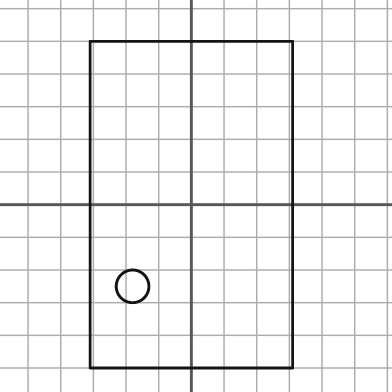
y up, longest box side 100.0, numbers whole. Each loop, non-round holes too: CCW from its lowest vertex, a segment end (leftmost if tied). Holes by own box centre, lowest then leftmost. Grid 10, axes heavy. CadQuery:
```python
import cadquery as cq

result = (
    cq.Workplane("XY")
    .moveTo(-31.0, -50.0)
    .lineTo(31.0, -50.0)
    .lineTo(31.0, 50.0)
    .lineTo(-31.0, 50.0)
    .close()
    .moveTo(-18.0, -25.0)
    .circle(5.0)
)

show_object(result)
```